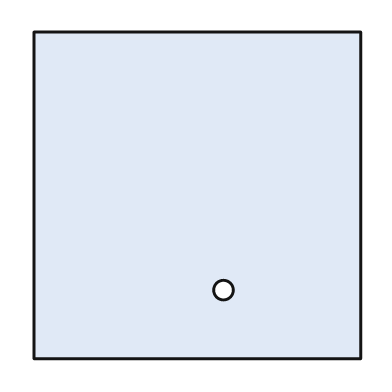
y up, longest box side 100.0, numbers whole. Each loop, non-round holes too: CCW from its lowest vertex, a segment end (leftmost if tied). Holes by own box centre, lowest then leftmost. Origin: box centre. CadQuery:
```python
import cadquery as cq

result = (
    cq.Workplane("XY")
    .moveTo(-50.0, -50.0)
    .lineTo(50.0, -50.0)
    .lineTo(50.0, 50.0)
    .lineTo(-50.0, 50.0)
    .close()
    .moveTo(8.0, -29.0)
    .circle(3.0)
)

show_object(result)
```